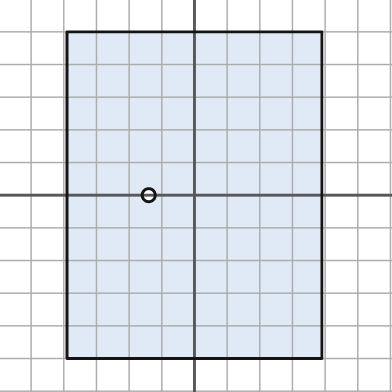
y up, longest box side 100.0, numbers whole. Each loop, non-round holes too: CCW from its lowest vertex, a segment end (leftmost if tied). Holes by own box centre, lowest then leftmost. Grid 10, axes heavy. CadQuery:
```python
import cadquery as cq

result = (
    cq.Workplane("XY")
    .moveTo(-39.0, -50.0)
    .lineTo(39.0, -50.0)
    .lineTo(39.0, 50.0)
    .lineTo(-39.0, 50.0)
    .close()
    .moveTo(-14.0, 0.0)
    .circle(2.0)
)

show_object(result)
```